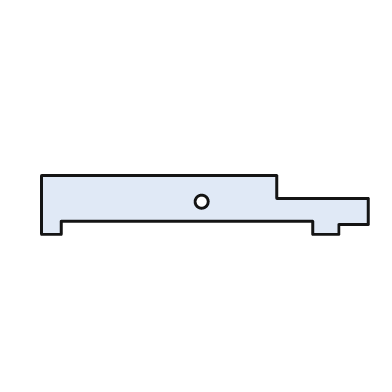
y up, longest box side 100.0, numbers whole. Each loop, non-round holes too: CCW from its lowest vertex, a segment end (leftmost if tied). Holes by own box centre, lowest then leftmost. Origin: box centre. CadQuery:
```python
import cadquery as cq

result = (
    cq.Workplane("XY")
    .moveTo(-50.0, -9.0)
    .lineTo(-44.0, -9.0)
    .lineTo(-44.0, -5.0)
    .lineTo(33.0, -5.0)
    .lineTo(33.0, -9.0)
    .lineTo(41.0, -9.0)
    .lineTo(41.0, -6.0)
    .lineTo(50.0, -6.0)
    .lineTo(50.0, 2.0)
    .lineTo(22.0, 2.0)
    .lineTo(22.0, 9.0)
    .lineTo(-50.0, 9.0)
    .close()
    .moveTo(-1.0, 1.0)
    .circle(2.0)
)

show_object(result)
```